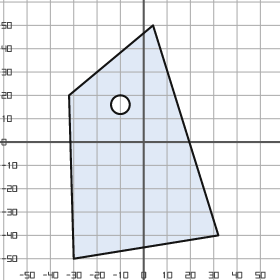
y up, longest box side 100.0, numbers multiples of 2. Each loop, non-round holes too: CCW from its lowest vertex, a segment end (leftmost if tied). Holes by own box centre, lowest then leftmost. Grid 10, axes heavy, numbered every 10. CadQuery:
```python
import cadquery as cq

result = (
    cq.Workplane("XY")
    .moveTo(-30.0, -50.0)
    .lineTo(32.0, -40.0)
    .lineTo(4.0, 50.0)
    .lineTo(-32.0, 20.0)
    .close()
    .moveTo(-10.0, 16.0)
    .circle(4.0)
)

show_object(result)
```